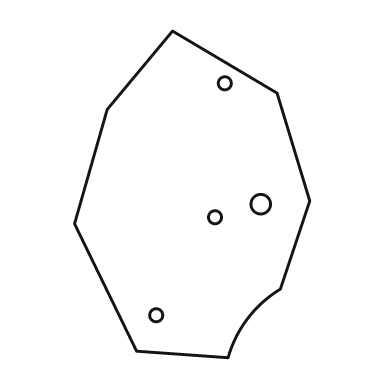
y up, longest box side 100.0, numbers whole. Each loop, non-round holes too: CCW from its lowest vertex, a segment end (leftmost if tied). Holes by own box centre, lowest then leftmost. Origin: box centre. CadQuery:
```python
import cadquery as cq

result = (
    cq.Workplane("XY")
    .moveTo(11.0, -50.0)
    .threePointArc((17.0, -38.0), (27.0, -29.0))
    .lineTo(36.0, -2.0)
    .lineTo(26.0, 31.0)
    .lineTo(-6.0, 50.0)
    .lineTo(-26.0, 26.0)
    .lineTo(-36.0, -9.0)
    .lineTo(-17.0, -48.0)
    .close()
    .moveTo(-11.0, -37.0)
    .circle(2.0)
    .moveTo(7.0, -7.0)
    .circle(2.0)
    .moveTo(21.0, -3.0)
    .circle(3.0)
    .moveTo(10.0, 34.0)
    .circle(2.0)
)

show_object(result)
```